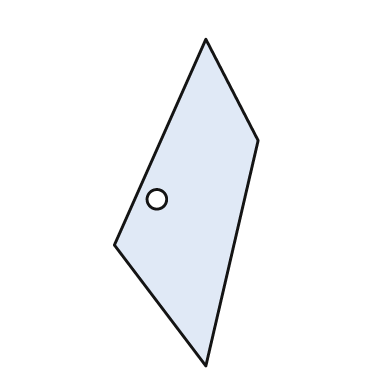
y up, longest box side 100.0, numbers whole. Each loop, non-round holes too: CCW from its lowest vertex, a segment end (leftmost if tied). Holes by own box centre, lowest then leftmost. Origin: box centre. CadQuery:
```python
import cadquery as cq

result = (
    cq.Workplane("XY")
    .moveTo(6.0, -50.0)
    .lineTo(22.0, 19.0)
    .lineTo(6.0, 50.0)
    .lineTo(-22.0, -13.0)
    .close()
    .moveTo(-9.0, 1.0)
    .circle(3.0)
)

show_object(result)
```